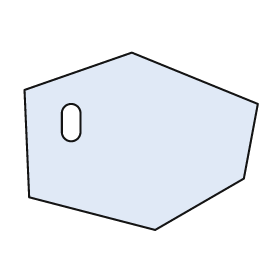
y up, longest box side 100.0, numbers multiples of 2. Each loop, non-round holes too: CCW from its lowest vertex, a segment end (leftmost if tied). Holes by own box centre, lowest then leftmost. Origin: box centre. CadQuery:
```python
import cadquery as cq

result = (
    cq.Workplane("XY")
    .moveTo(6.0, -38.0)
    .lineTo(44.0, -16.0)
    .lineTo(50.0, 16.0)
    .lineTo(-4.0, 38.0)
    .lineTo(-50.0, 22.0)
    .lineTo(-48.0, -24.0)
    .close()
    .moveTo(-34.0, 4.0)
    .threePointArc((-30.0, 0.0), (-26.0, 4.0))
    .lineTo(-26.0, 12.0)
    .threePointArc((-30.0, 16.0), (-34.0, 12.0))
    .close()
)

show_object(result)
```